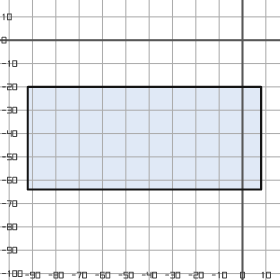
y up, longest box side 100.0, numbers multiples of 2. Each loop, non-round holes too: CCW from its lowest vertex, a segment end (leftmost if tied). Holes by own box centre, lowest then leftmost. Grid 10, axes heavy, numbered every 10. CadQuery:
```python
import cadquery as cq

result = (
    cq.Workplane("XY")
    .moveTo(-92.0, -64.0)
    .lineTo(8.0, -64.0)
    .lineTo(8.0, -20.0)
    .lineTo(-92.0, -20.0)
    .close()
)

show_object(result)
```